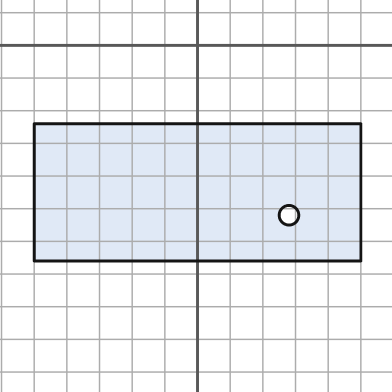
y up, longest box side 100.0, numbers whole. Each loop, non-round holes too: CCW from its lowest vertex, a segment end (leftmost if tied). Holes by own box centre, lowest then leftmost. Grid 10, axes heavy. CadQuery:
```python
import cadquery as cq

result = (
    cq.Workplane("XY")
    .moveTo(-50.0, -66.0)
    .lineTo(50.0, -66.0)
    .lineTo(50.0, -24.0)
    .lineTo(-50.0, -24.0)
    .close()
    .moveTo(28.0, -52.0)
    .circle(3.0)
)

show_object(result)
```